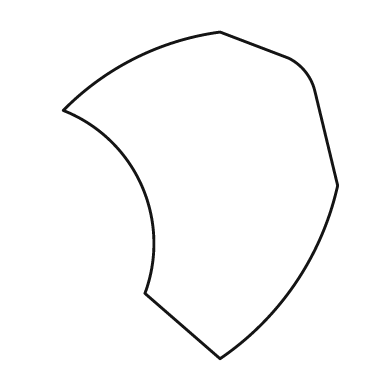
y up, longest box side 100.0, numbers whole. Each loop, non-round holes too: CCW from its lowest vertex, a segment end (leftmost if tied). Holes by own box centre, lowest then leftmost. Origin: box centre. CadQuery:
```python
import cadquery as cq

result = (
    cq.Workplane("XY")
    .moveTo(6.0, -50.0)
    .threePointArc((29.0, -27.0), (42.0, 3.0))
    .lineTo(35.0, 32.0)
    .threePointArc((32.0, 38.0), (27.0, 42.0))
    .lineTo(6.0, 50.0)
    .threePointArc((-20.0, 42.0), (-42.0, 26.0))
    .threePointArc((-18.0, 3.0), (-17.0, -30.0))
    .close()
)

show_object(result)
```